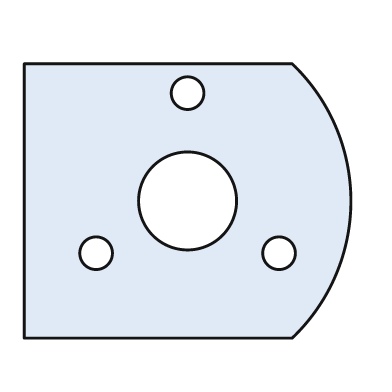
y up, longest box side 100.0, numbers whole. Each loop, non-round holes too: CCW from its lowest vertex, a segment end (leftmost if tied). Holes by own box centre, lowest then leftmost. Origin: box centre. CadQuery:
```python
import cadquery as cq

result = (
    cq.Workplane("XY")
    .moveTo(-50.0, -42.0)
    .lineTo(32.0, -42.0)
    .threePointArc((50.0, 0.0), (32.0, 42.0))
    .lineTo(-50.0, 42.0)
    .close()
    .moveTo(-28.0, -16.0)
    .circle(5.0)
    .moveTo(28.0, -16.0)
    .circle(5.0)
    .moveTo(0.0, 0.0)
    .circle(15.0)
    .moveTo(0.0, 33.0)
    .circle(5.0)
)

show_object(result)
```